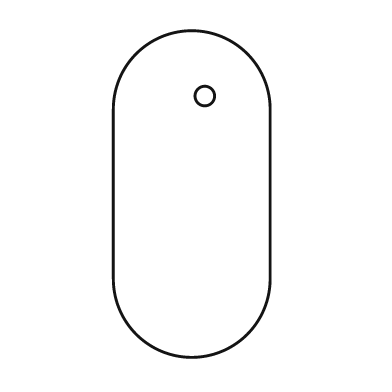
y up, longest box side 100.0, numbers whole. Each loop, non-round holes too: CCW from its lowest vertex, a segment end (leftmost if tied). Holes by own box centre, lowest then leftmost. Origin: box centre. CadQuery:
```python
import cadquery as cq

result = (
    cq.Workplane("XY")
    .moveTo(-24.0, -26.0)
    .threePointArc((0.0, -50.0), (24.0, -26.0))
    .lineTo(24.0, 26.0)
    .threePointArc((0.0, 50.0), (-24.0, 26.0))
    .close()
    .moveTo(4.0, 30.0)
    .circle(3.0)
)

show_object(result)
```